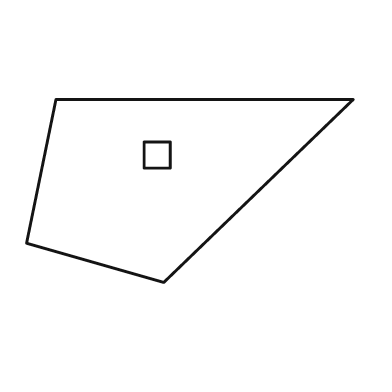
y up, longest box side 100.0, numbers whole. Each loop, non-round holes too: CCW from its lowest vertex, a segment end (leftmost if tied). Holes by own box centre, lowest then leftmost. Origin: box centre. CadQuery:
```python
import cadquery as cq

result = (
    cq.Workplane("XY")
    .moveTo(-8.0, -28.0)
    .lineTo(50.0, 28.0)
    .lineTo(-41.0, 28.0)
    .lineTo(-50.0, -16.0)
    .close()
    .moveTo(-14.0, 7.0)
    .lineTo(-6.0, 7.0)
    .lineTo(-6.0, 15.0)
    .lineTo(-14.0, 15.0)
    .close()
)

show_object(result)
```